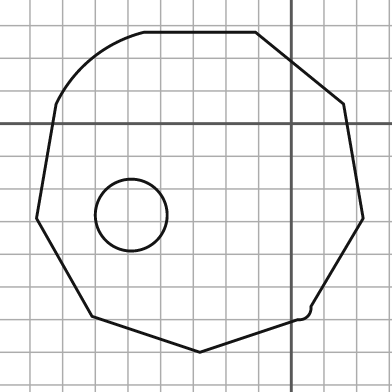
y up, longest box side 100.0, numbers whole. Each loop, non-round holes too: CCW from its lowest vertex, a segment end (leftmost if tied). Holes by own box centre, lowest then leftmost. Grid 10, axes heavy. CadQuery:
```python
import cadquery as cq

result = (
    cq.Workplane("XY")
    .moveTo(-28.0, -70.0)
    .lineTo(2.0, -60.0)
    .threePointArc((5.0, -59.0), (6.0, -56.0))
    .lineTo(22.0, -29.0)
    .lineTo(16.0, 6.0)
    .lineTo(-11.0, 28.0)
    .lineTo(-45.0, 28.0)
    .threePointArc((-61.0, 20.0), (-72.0, 6.0))
    .lineTo(-78.0, -29.0)
    .lineTo(-61.0, -59.0)
    .close()
    .moveTo(-49.0, -28.0)
    .circle(11.0)
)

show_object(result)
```